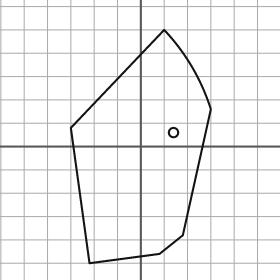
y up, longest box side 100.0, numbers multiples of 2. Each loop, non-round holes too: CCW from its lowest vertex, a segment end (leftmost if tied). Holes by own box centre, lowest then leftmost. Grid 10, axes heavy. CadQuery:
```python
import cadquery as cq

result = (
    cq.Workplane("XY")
    .moveTo(-22.0, -50.0)
    .lineTo(8.0, -46.0)
    .lineTo(18.0, -38.0)
    .lineTo(30.0, 16.0)
    .threePointArc((22.0, 34.0), (10.0, 50.0))
    .lineTo(-30.0, 8.0)
    .close()
    .moveTo(14.0, 6.0)
    .circle(2.0)
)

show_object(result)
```